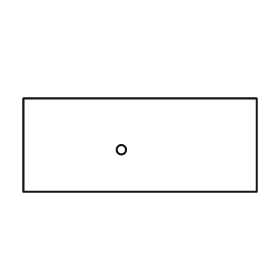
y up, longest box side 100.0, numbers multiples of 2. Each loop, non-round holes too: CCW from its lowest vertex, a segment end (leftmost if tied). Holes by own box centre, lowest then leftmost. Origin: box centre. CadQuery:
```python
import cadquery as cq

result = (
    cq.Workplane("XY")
    .moveTo(-50.0, -20.0)
    .lineTo(50.0, -20.0)
    .lineTo(50.0, 20.0)
    .lineTo(-50.0, 20.0)
    .close()
    .moveTo(-8.0, -2.0)
    .circle(2.0)
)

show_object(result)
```